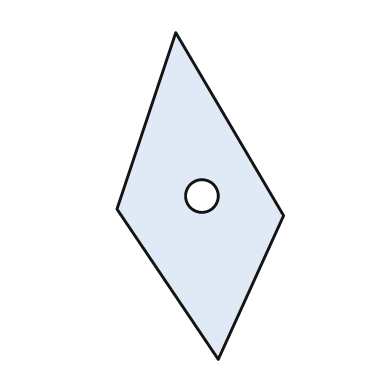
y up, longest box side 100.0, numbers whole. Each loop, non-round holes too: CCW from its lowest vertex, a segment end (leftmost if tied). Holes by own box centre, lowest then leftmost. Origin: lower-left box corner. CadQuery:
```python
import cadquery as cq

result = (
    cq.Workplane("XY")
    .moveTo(31.0, 0.0)
    .lineTo(51.0, 44.0)
    .lineTo(18.0, 100.0)
    .lineTo(0.0, 46.0)
    .close()
    .moveTo(26.0, 50.0)
    .circle(5.0)
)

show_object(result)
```